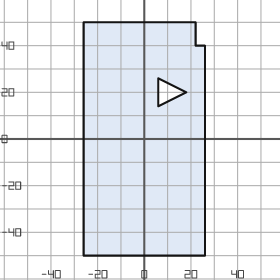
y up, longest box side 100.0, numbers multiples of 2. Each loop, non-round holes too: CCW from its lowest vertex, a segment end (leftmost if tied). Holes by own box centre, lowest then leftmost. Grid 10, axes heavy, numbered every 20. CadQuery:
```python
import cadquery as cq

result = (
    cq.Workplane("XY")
    .moveTo(-26.0, -50.0)
    .lineTo(26.0, -50.0)
    .lineTo(26.0, 40.0)
    .lineTo(22.0, 40.0)
    .lineTo(22.0, 50.0)
    .lineTo(-26.0, 50.0)
    .close()
    .moveTo(6.0, 14.0)
    .lineTo(18.0, 20.0)
    .lineTo(6.0, 26.0)
    .close()
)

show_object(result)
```